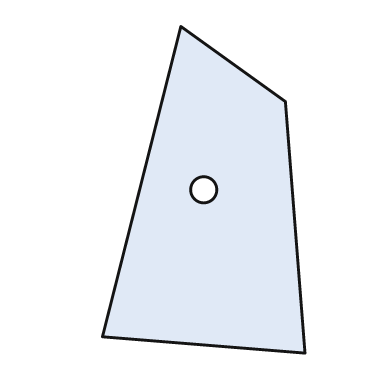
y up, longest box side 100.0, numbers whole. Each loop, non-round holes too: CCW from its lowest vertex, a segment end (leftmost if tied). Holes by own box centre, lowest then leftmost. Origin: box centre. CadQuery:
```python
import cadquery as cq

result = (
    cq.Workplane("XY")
    .moveTo(31.0, -50.0)
    .lineTo(25.0, 27.0)
    .lineTo(-7.0, 50.0)
    .lineTo(-31.0, -45.0)
    .close()
    .moveTo(0.0, 0.0)
    .circle(4.0)
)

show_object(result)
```